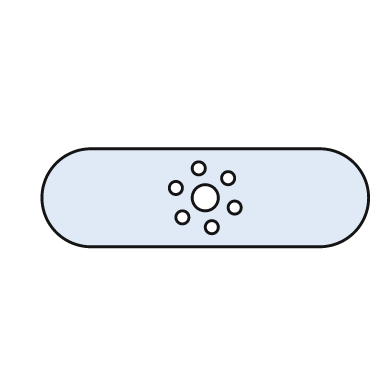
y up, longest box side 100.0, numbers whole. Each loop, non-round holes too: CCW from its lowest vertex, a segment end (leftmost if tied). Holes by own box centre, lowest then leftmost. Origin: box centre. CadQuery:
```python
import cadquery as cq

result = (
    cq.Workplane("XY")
    .moveTo(-35.0, -15.0)
    .lineTo(35.0, -15.0)
    .threePointArc((50.0, 0.0), (35.0, 15.0))
    .lineTo(-35.0, 15.0)
    .threePointArc((-50.0, 0.0), (-35.0, -15.0))
    .close()
    .moveTo(2.0, -9.0)
    .circle(2.0)
    .moveTo(-7.0, -6.0)
    .circle(2.0)
    .moveTo(9.0, -3.0)
    .circle(2.0)
    .moveTo(0.0, 0.0)
    .circle(4.0)
    .moveTo(-9.0, 3.0)
    .circle(2.0)
    .moveTo(7.0, 6.0)
    .circle(2.0)
    .moveTo(-2.0, 9.0)
    .circle(2.0)
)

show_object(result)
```